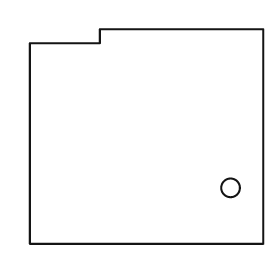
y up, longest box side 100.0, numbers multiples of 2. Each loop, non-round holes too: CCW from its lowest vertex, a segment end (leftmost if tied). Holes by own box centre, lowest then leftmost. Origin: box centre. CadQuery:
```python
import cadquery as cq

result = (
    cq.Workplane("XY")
    .moveTo(-50.0, -46.0)
    .lineTo(50.0, -46.0)
    .lineTo(50.0, 46.0)
    .lineTo(-20.0, 46.0)
    .lineTo(-20.0, 40.0)
    .lineTo(-50.0, 40.0)
    .close()
    .moveTo(36.0, -22.0)
    .circle(4.0)
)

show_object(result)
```